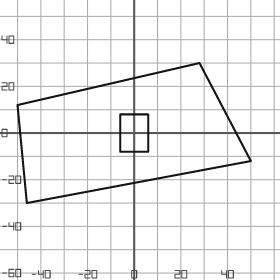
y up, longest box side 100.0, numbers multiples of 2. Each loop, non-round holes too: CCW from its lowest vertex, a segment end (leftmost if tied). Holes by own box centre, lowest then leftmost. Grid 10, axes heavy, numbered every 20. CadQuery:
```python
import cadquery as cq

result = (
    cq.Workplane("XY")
    .moveTo(-46.0, -30.0)
    .lineTo(50.0, -12.0)
    .lineTo(28.0, 30.0)
    .lineTo(-50.0, 12.0)
    .close()
    .moveTo(-6.0, -8.0)
    .lineTo(6.0, -8.0)
    .lineTo(6.0, 8.0)
    .lineTo(-6.0, 8.0)
    .close()
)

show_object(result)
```